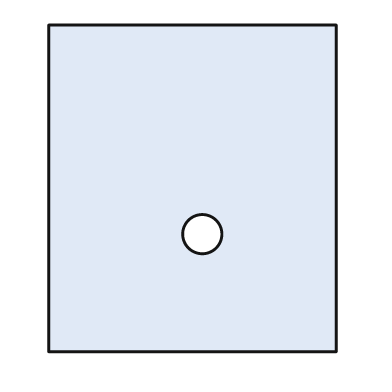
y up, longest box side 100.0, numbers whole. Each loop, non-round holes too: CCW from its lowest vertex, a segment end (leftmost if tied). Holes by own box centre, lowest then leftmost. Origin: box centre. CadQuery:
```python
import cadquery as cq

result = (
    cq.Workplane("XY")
    .moveTo(-44.0, -50.0)
    .lineTo(44.0, -50.0)
    .lineTo(44.0, 50.0)
    .lineTo(-44.0, 50.0)
    .close()
    .moveTo(3.0, -14.0)
    .circle(6.0)
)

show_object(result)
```